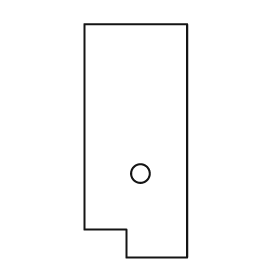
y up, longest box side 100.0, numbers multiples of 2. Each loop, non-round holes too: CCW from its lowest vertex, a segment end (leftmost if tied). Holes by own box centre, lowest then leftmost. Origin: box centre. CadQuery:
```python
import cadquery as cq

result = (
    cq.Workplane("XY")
    .moveTo(-4.0, -50.0)
    .lineTo(22.0, -50.0)
    .lineTo(22.0, 50.0)
    .lineTo(-22.0, 50.0)
    .lineTo(-22.0, -38.0)
    .lineTo(-4.0, -38.0)
    .close()
    .moveTo(2.0, -14.0)
    .circle(4.0)
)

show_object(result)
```